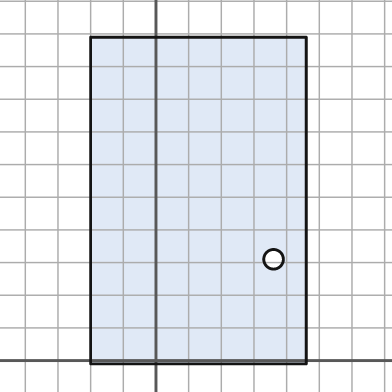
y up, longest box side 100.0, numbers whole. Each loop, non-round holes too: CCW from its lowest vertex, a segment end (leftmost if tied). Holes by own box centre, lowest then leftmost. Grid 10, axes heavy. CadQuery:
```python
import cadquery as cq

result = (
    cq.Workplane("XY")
    .moveTo(-20.0, -1.0)
    .lineTo(46.0, -1.0)
    .lineTo(46.0, 99.0)
    .lineTo(-20.0, 99.0)
    .close()
    .moveTo(36.0, 31.0)
    .circle(3.0)
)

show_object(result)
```